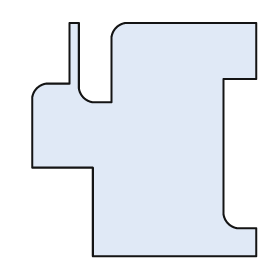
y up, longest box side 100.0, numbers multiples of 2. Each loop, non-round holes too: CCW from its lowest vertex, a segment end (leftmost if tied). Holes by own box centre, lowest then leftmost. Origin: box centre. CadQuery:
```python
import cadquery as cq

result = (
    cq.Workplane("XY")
    .moveTo(-22.0, -50.0)
    .lineTo(48.0, -50.0)
    .lineTo(48.0, -38.0)
    .lineTo(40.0, -38.0)
    .threePointArc((36.0, -36.0), (34.0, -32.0))
    .lineTo(34.0, 26.0)
    .lineTo(48.0, 26.0)
    .lineTo(48.0, 50.0)
    .lineTo(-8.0, 50.0)
    .threePointArc((-12.0, 48.0), (-14.0, 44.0))
    .lineTo(-14.0, 16.0)
    .lineTo(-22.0, 16.0)
    .threePointArc((-26.0, 18.0), (-28.0, 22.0))
    .lineTo(-28.0, 50.0)
    .lineTo(-32.0, 50.0)
    .lineTo(-32.0, 24.0)
    .lineTo(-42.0, 24.0)
    .threePointArc((-46.0, 22.0), (-48.0, 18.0))
    .lineTo(-48.0, -12.0)
    .lineTo(-22.0, -12.0)
    .close()
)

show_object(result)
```